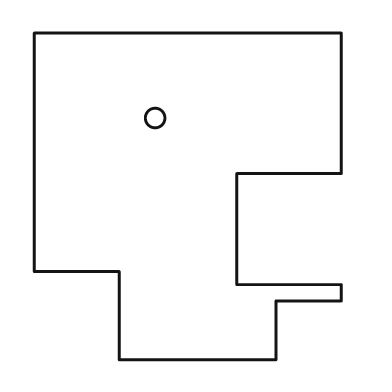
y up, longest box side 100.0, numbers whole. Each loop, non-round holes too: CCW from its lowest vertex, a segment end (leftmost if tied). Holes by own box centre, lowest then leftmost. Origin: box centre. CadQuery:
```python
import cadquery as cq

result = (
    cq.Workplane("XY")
    .moveTo(-21.0, -50.0)
    .lineTo(27.0, -50.0)
    .lineTo(27.0, -32.0)
    .lineTo(47.0, -32.0)
    .lineTo(47.0, -27.0)
    .lineTo(15.0, -27.0)
    .lineTo(15.0, 7.0)
    .lineTo(47.0, 7.0)
    .lineTo(47.0, 50.0)
    .lineTo(-47.0, 50.0)
    .lineTo(-47.0, -23.0)
    .lineTo(-21.0, -23.0)
    .close()
    .moveTo(-10.0, 24.0)
    .circle(3.0)
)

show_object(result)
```